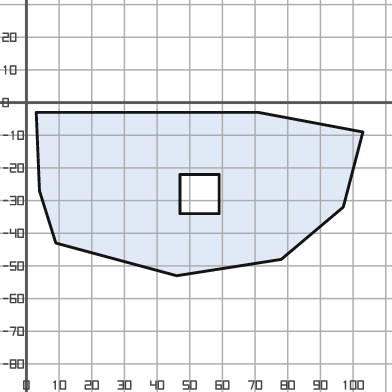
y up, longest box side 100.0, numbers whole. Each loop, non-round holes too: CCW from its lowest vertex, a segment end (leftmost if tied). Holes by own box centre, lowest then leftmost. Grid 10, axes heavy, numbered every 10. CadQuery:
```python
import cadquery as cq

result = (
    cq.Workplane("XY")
    .moveTo(46.0, -53.0)
    .lineTo(78.0, -48.0)
    .lineTo(97.0, -32.0)
    .lineTo(103.0, -9.0)
    .lineTo(71.0, -3.0)
    .lineTo(3.0, -3.0)
    .lineTo(4.0, -27.0)
    .lineTo(9.0, -43.0)
    .close()
    .moveTo(47.0, -34.0)
    .lineTo(59.0, -34.0)
    .lineTo(59.0, -22.0)
    .lineTo(47.0, -22.0)
    .close()
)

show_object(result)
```